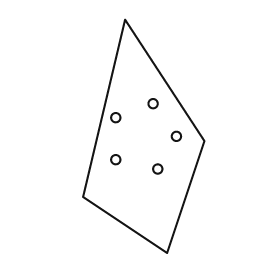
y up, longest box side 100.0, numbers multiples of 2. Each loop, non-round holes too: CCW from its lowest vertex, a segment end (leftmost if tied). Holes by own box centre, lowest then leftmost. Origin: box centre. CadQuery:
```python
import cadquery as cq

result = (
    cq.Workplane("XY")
    .moveTo(10.0, -50.0)
    .lineTo(26.0, -2.0)
    .lineTo(-8.0, 50.0)
    .lineTo(-26.0, -26.0)
    .close()
    .moveTo(6.0, -14.0)
    .circle(2.0)
    .moveTo(-12.0, -10.0)
    .circle(2.0)
    .moveTo(14.0, 0.0)
    .circle(2.0)
    .moveTo(-12.0, 8.0)
    .circle(2.0)
    .moveTo(4.0, 14.0)
    .circle(2.0)
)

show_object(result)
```